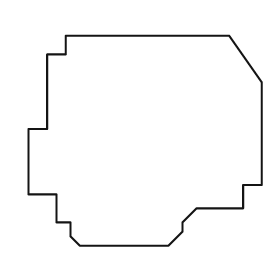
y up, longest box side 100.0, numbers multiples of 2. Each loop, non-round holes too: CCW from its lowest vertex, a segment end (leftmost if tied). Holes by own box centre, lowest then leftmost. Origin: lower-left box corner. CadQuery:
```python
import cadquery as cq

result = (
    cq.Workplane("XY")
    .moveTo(22.0, 0.0)
    .lineTo(60.0, 0.0)
    .lineTo(66.0, 6.0)
    .lineTo(66.0, 10.0)
    .lineTo(72.0, 16.0)
    .lineTo(92.0, 16.0)
    .lineTo(92.0, 26.0)
    .lineTo(100.0, 26.0)
    .lineTo(100.0, 70.0)
    .lineTo(86.0, 90.0)
    .lineTo(16.0, 90.0)
    .lineTo(16.0, 82.0)
    .lineTo(8.0, 82.0)
    .lineTo(8.0, 50.0)
    .lineTo(0.0, 50.0)
    .lineTo(0.0, 22.0)
    .lineTo(12.0, 22.0)
    .lineTo(12.0, 10.0)
    .lineTo(18.0, 10.0)
    .lineTo(18.0, 4.0)
    .close()
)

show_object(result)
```